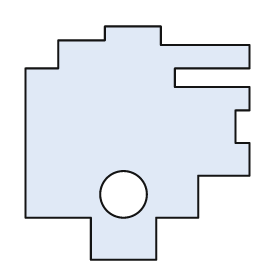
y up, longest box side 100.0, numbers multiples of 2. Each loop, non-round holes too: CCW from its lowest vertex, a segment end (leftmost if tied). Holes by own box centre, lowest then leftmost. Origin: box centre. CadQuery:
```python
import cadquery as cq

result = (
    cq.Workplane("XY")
    .moveTo(-20.0, -50.0)
    .lineTo(8.0, -50.0)
    .lineTo(8.0, -32.0)
    .lineTo(26.0, -32.0)
    .lineTo(26.0, -14.0)
    .lineTo(48.0, -14.0)
    .lineTo(48.0, 0.0)
    .lineTo(42.0, 0.0)
    .lineTo(42.0, 14.0)
    .lineTo(48.0, 14.0)
    .lineTo(48.0, 24.0)
    .lineTo(16.0, 24.0)
    .lineTo(16.0, 32.0)
    .lineTo(48.0, 32.0)
    .lineTo(48.0, 42.0)
    .lineTo(10.0, 42.0)
    .lineTo(10.0, 50.0)
    .lineTo(-14.0, 50.0)
    .lineTo(-14.0, 44.0)
    .lineTo(-34.0, 44.0)
    .lineTo(-34.0, 32.0)
    .lineTo(-48.0, 32.0)
    .lineTo(-48.0, -32.0)
    .lineTo(-20.0, -32.0)
    .close()
    .moveTo(-6.0, -22.0)
    .circle(10.0)
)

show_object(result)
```